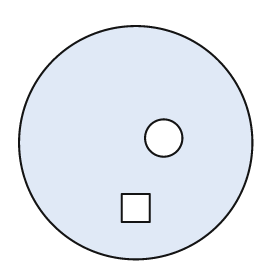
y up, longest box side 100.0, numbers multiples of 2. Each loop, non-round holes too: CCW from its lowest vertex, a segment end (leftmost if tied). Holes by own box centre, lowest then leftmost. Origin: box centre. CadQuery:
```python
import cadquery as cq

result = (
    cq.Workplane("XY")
    .moveTo(0.0, 0.0)
    .circle(50.0)
    .moveTo(-6.0, -34.0)
    .lineTo(6.0, -34.0)
    .lineTo(6.0, -22.0)
    .lineTo(-6.0, -22.0)
    .close()
    .moveTo(12.0, 2.0)
    .circle(8.0)
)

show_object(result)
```